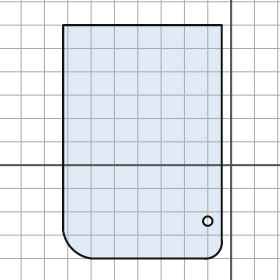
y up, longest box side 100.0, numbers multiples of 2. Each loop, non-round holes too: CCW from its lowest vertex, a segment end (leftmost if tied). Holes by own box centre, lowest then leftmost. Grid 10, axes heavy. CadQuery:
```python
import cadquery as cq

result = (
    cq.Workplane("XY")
    .moveTo(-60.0, -40.0)
    .lineTo(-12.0, -40.0)
    .threePointArc((-6.0, -38.0), (-4.0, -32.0))
    .lineTo(-4.0, 60.0)
    .lineTo(-72.0, 60.0)
    .lineTo(-72.0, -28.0)
    .threePointArc((-68.0, -36.0), (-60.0, -40.0))
    .close()
    .moveTo(-10.0, -24.0)
    .circle(2.0)
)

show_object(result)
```